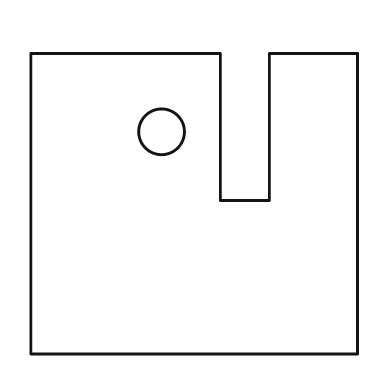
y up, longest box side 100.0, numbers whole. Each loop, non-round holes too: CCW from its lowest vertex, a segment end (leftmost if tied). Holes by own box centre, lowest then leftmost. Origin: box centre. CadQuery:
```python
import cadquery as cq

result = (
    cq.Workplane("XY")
    .moveTo(-50.0, -46.0)
    .lineTo(50.0, -46.0)
    .lineTo(50.0, 46.0)
    .lineTo(23.0, 46.0)
    .lineTo(23.0, 1.0)
    .lineTo(8.0, 1.0)
    .lineTo(8.0, 46.0)
    .lineTo(-50.0, 46.0)
    .close()
    .moveTo(-10.0, 22.0)
    .circle(7.0)
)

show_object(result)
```